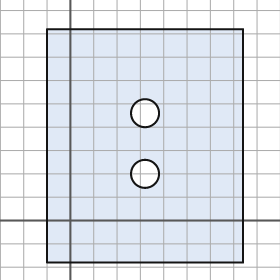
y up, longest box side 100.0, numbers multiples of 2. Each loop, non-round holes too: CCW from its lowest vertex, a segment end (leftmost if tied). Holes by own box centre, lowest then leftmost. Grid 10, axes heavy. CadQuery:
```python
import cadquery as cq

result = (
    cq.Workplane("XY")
    .moveTo(-10.0, -18.0)
    .lineTo(74.0, -18.0)
    .lineTo(74.0, 82.0)
    .lineTo(-10.0, 82.0)
    .close()
    .moveTo(32.0, 20.0)
    .circle(6.0)
    .moveTo(32.0, 46.0)
    .circle(6.0)
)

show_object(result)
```